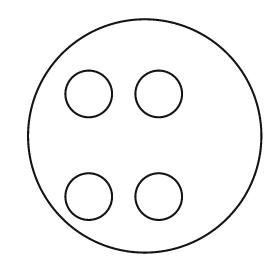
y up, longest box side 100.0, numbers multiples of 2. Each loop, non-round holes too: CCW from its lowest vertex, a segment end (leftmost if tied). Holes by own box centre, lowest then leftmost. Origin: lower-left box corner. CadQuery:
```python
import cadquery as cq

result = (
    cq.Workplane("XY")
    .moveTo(50.0, 50.0)
    .circle(50.0)
    .moveTo(26.0, 24.0)
    .circle(10.0)
    .moveTo(56.0, 24.0)
    .circle(10.0)
    .moveTo(26.0, 68.0)
    .circle(10.0)
    .moveTo(56.0, 68.0)
    .circle(10.0)
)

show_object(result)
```